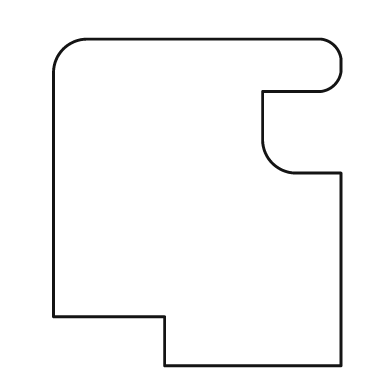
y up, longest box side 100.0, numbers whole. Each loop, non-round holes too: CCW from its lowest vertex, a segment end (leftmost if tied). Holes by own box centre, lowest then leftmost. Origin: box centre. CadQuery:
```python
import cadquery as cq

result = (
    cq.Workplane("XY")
    .moveTo(-10.0, -50.0)
    .lineTo(44.0, -50.0)
    .lineTo(44.0, 9.0)
    .lineTo(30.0, 9.0)
    .threePointArc((23.0, 12.0), (20.0, 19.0))
    .lineTo(20.0, 34.0)
    .lineTo(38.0, 34.0)
    .threePointArc((42.0, 36.0), (44.0, 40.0))
    .lineTo(44.0, 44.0)
    .threePointArc((42.0, 48.0), (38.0, 50.0))
    .lineTo(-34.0, 50.0)
    .threePointArc((-41.0, 47.0), (-44.0, 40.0))
    .lineTo(-44.0, -35.0)
    .lineTo(-10.0, -35.0)
    .close()
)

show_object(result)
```